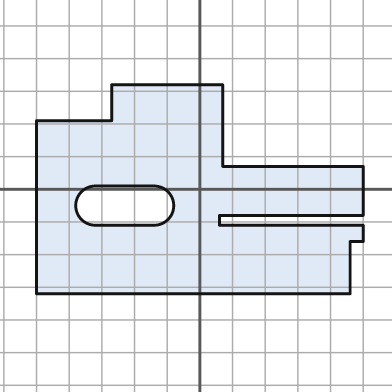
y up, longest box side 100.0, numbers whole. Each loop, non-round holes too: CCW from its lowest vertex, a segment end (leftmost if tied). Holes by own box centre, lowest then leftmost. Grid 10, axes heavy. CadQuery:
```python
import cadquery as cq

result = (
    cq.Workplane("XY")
    .moveTo(-50.0, -32.0)
    .lineTo(46.0, -32.0)
    .lineTo(46.0, -16.0)
    .lineTo(50.0, -16.0)
    .lineTo(50.0, -11.0)
    .lineTo(6.0, -11.0)
    .lineTo(6.0, -8.0)
    .lineTo(50.0, -8.0)
    .lineTo(50.0, 7.0)
    .lineTo(7.0, 7.0)
    .lineTo(7.0, 32.0)
    .lineTo(-27.0, 32.0)
    .lineTo(-27.0, 21.0)
    .lineTo(-50.0, 21.0)
    .close()
    .moveTo(-32.0, -11.0)
    .lineTo(-14.0, -11.0)
    .threePointArc((-8.0, -5.0), (-14.0, 1.0))
    .lineTo(-32.0, 1.0)
    .threePointArc((-38.0, -5.0), (-32.0, -11.0))
    .close()
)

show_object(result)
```